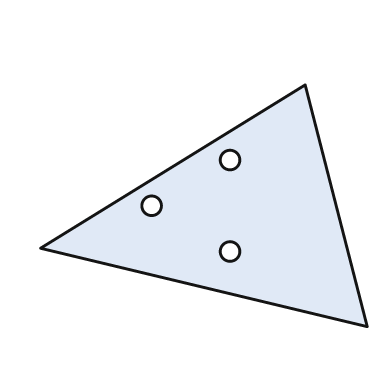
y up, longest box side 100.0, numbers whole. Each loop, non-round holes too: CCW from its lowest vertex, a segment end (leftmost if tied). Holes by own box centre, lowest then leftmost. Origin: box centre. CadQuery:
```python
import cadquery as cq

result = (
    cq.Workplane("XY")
    .moveTo(50.0, -37.0)
    .lineTo(31.0, 37.0)
    .lineTo(-50.0, -13.0)
    .close()
    .moveTo(8.0, -14.0)
    .circle(3.0)
    .moveTo(-16.0, 0.0)
    .circle(3.0)
    .moveTo(8.0, 14.0)
    .circle(3.0)
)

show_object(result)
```